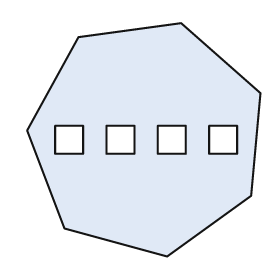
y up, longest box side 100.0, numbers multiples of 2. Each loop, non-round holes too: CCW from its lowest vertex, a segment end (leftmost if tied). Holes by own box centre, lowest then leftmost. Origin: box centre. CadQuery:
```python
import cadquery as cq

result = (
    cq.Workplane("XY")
    .moveTo(10.0, -50.0)
    .lineTo(46.0, -24.0)
    .lineTo(50.0, 20.0)
    .lineTo(16.0, 50.0)
    .lineTo(-28.0, 44.0)
    .lineTo(-50.0, 4.0)
    .lineTo(-34.0, -38.0)
    .close()
    .moveTo(-38.0, -6.0)
    .lineTo(-26.0, -6.0)
    .lineTo(-26.0, 6.0)
    .lineTo(-38.0, 6.0)
    .close()
    .moveTo(-16.0, -6.0)
    .lineTo(-4.0, -6.0)
    .lineTo(-4.0, 6.0)
    .lineTo(-16.0, 6.0)
    .close()
    .moveTo(6.0, -6.0)
    .lineTo(18.0, -6.0)
    .lineTo(18.0, 6.0)
    .lineTo(6.0, 6.0)
    .close()
    .moveTo(28.0, -6.0)
    .lineTo(40.0, -6.0)
    .lineTo(40.0, 6.0)
    .lineTo(28.0, 6.0)
    .close()
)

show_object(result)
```